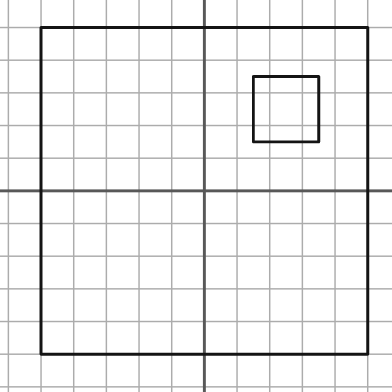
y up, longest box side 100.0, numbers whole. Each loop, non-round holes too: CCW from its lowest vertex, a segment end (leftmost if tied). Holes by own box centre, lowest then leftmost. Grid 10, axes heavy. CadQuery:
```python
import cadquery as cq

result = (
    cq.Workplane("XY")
    .moveTo(-50.0, -50.0)
    .lineTo(50.0, -50.0)
    .lineTo(50.0, 50.0)
    .lineTo(-50.0, 50.0)
    .close()
    .moveTo(15.0, 15.0)
    .lineTo(35.0, 15.0)
    .lineTo(35.0, 35.0)
    .lineTo(15.0, 35.0)
    .close()
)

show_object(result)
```